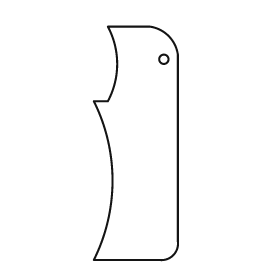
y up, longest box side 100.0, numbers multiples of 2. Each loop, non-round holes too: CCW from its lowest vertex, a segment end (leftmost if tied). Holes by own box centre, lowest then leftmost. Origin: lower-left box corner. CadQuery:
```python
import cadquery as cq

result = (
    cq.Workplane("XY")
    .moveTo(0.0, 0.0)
    .lineTo(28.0, 0.0)
    .threePointArc((34.0, 2.0), (36.0, 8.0))
    .lineTo(36.0, 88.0)
    .threePointArc((32.0, 96.0), (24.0, 100.0))
    .lineTo(6.0, 100.0)
    .threePointArc((10.0, 84.0), (6.0, 68.0))
    .lineTo(0.0, 68.0)
    .threePointArc((8.0, 34.0), (0.0, 0.0))
    .close()
    .moveTo(30.0, 86.0)
    .circle(2.0)
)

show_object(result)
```